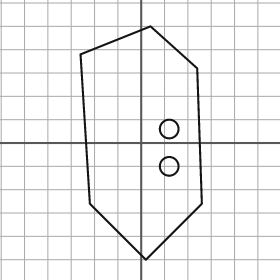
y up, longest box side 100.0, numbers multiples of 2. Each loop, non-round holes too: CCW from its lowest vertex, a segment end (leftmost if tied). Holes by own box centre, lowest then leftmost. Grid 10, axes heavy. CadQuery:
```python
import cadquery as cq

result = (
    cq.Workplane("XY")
    .moveTo(2.0, -50.0)
    .lineTo(26.0, -26.0)
    .lineTo(24.0, 32.0)
    .lineTo(4.0, 50.0)
    .lineTo(-26.0, 38.0)
    .lineTo(-22.0, -26.0)
    .close()
    .moveTo(12.0, -10.0)
    .circle(4.0)
    .moveTo(12.0, 6.0)
    .circle(4.0)
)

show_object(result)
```